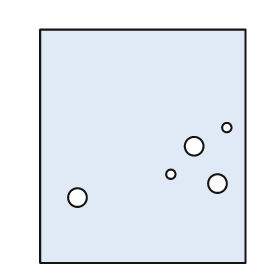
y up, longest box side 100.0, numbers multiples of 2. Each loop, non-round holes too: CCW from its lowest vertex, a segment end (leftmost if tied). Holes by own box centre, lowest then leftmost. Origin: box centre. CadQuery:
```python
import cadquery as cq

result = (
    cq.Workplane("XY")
    .moveTo(-44.0, -50.0)
    .lineTo(44.0, -50.0)
    .lineTo(44.0, 50.0)
    .lineTo(-44.0, 50.0)
    .close()
    .moveTo(-28.0, -22.0)
    .circle(4.0)
    .moveTo(32.0, -16.0)
    .circle(4.0)
    .moveTo(12.0, -12.0)
    .circle(2.0)
    .moveTo(22.0, 0.0)
    .circle(4.0)
    .moveTo(36.0, 8.0)
    .circle(2.0)
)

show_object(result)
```